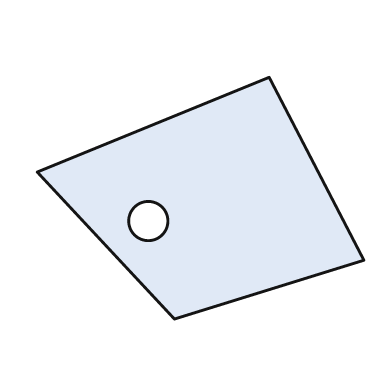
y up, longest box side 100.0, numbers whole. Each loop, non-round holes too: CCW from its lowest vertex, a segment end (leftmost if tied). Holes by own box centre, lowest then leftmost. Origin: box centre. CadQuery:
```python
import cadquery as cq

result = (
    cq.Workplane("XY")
    .moveTo(-8.0, -37.0)
    .lineTo(50.0, -19.0)
    .lineTo(21.0, 37.0)
    .lineTo(-50.0, 8.0)
    .close()
    .moveTo(-16.0, -7.0)
    .circle(6.0)
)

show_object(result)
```